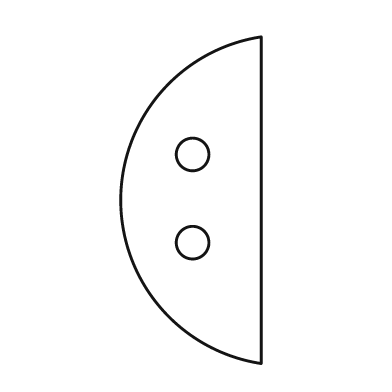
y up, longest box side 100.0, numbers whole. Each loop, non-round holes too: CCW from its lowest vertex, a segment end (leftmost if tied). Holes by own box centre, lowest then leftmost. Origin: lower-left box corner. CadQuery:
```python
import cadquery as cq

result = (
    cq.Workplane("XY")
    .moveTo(43.0, 0.0)
    .lineTo(43.0, 100.0)
    .threePointArc((0.0, 50.0), (43.0, 0.0))
    .close()
    .moveTo(22.0, 37.0)
    .circle(5.0)
    .moveTo(22.0, 64.0)
    .circle(5.0)
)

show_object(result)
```